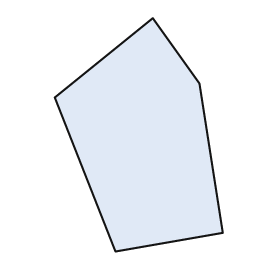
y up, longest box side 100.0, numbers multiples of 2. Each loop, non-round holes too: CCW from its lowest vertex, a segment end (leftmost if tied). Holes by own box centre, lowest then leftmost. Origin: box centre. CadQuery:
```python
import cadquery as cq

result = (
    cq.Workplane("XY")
    .moveTo(-10.0, -50.0)
    .lineTo(36.0, -42.0)
    .lineTo(26.0, 22.0)
    .lineTo(6.0, 50.0)
    .lineTo(-36.0, 16.0)
    .close()
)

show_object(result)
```